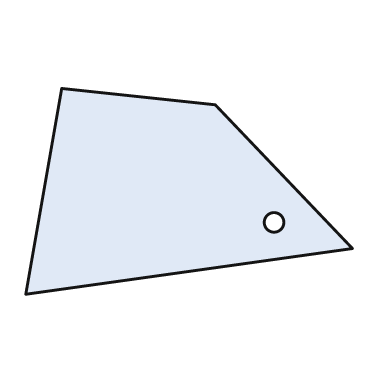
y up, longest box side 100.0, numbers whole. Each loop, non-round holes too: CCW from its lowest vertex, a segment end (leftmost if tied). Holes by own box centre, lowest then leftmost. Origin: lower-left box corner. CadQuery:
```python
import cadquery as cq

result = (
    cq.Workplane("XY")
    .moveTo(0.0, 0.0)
    .lineTo(100.0, 14.0)
    .lineTo(58.0, 58.0)
    .lineTo(11.0, 63.0)
    .close()
    .moveTo(76.0, 22.0)
    .circle(3.0)
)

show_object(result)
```